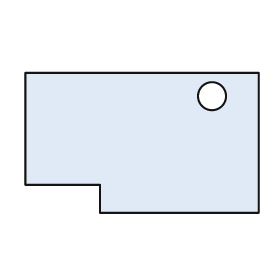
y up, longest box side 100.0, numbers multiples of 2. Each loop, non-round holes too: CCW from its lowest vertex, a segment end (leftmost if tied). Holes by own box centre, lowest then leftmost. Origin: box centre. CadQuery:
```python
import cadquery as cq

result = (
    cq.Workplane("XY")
    .moveTo(-18.0, -30.0)
    .lineTo(50.0, -30.0)
    .lineTo(50.0, 30.0)
    .lineTo(-50.0, 30.0)
    .lineTo(-50.0, -18.0)
    .lineTo(-18.0, -18.0)
    .close()
    .moveTo(30.0, 20.0)
    .circle(6.0)
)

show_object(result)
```